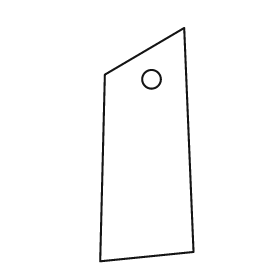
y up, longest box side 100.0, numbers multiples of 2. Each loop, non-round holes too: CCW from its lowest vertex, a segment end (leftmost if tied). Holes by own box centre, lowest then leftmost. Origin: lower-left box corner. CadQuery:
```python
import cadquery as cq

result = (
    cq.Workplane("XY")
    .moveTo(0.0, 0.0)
    .lineTo(40.0, 4.0)
    .lineTo(36.0, 100.0)
    .lineTo(2.0, 80.0)
    .close()
    .moveTo(22.0, 78.0)
    .circle(4.0)
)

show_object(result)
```